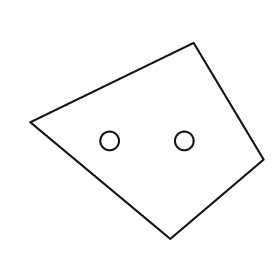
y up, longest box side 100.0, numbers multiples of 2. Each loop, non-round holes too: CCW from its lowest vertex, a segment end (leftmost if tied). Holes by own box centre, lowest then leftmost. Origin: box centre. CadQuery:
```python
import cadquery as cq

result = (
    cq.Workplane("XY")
    .moveTo(10.0, -42.0)
    .lineTo(50.0, -8.0)
    .lineTo(20.0, 42.0)
    .lineTo(-50.0, 8.0)
    .close()
    .moveTo(-16.0, 0.0)
    .circle(4.0)
    .moveTo(16.0, 0.0)
    .circle(4.0)
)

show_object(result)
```